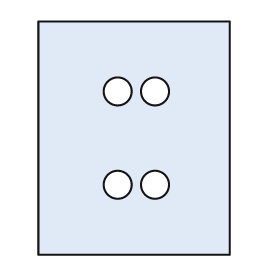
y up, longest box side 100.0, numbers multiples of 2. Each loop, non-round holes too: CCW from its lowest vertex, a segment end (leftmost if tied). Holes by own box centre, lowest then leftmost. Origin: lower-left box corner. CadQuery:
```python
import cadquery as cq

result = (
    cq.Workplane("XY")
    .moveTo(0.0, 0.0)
    .lineTo(82.0, 0.0)
    .lineTo(82.0, 100.0)
    .lineTo(0.0, 100.0)
    .close()
    .moveTo(34.0, 30.0)
    .circle(6.0)
    .moveTo(50.0, 30.0)
    .circle(6.0)
    .moveTo(34.0, 70.0)
    .circle(6.0)
    .moveTo(50.0, 70.0)
    .circle(6.0)
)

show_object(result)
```